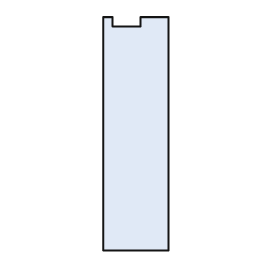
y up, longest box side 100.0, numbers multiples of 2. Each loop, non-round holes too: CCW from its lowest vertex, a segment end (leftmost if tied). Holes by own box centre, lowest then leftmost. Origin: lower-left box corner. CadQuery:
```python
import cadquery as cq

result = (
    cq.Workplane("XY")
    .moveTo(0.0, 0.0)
    .lineTo(28.0, 0.0)
    .lineTo(28.0, 100.0)
    .lineTo(16.0, 100.0)
    .lineTo(16.0, 96.0)
    .lineTo(4.0, 96.0)
    .lineTo(4.0, 100.0)
    .lineTo(0.0, 100.0)
    .close()
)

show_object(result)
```